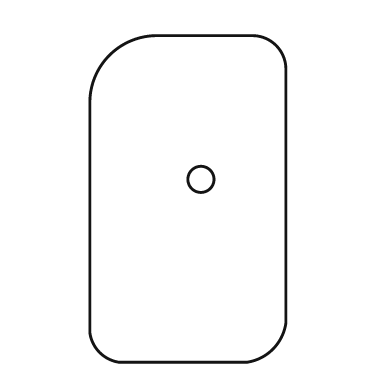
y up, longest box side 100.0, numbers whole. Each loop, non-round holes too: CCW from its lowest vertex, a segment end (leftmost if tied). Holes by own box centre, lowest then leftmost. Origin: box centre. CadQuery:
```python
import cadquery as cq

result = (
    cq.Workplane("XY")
    .moveTo(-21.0, -50.0)
    .lineTo(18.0, -50.0)
    .threePointArc((26.0, -46.0), (30.0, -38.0))
    .lineTo(30.0, 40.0)
    .threePointArc((27.0, 47.0), (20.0, 50.0))
    .lineTo(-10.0, 50.0)
    .threePointArc((-24.0, 44.0), (-30.0, 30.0))
    .lineTo(-30.0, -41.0)
    .threePointArc((-27.0, -47.0), (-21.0, -50.0))
    .close()
    .moveTo(4.0, 6.0)
    .circle(4.0)
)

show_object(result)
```